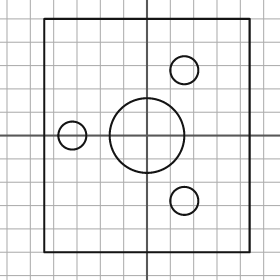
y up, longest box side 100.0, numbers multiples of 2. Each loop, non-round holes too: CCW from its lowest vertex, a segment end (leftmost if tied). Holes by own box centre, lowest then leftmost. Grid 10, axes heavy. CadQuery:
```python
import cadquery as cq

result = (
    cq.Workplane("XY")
    .moveTo(-44.0, -50.0)
    .lineTo(44.0, -50.0)
    .lineTo(44.0, 50.0)
    .lineTo(-44.0, 50.0)
    .close()
    .moveTo(16.0, -28.0)
    .circle(6.0)
    .moveTo(-32.0, 0.0)
    .circle(6.0)
    .moveTo(0.0, 0.0)
    .circle(16.0)
    .moveTo(16.0, 28.0)
    .circle(6.0)
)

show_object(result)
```